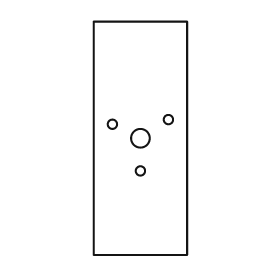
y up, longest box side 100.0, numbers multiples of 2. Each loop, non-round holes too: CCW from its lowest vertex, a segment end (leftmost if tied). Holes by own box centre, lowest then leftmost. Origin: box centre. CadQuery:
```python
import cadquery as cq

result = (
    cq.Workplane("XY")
    .moveTo(-20.0, -50.0)
    .lineTo(20.0, -50.0)
    .lineTo(20.0, 50.0)
    .lineTo(-20.0, 50.0)
    .close()
    .moveTo(0.0, -14.0)
    .circle(2.0)
    .moveTo(0.0, 0.0)
    .circle(4.0)
    .moveTo(-12.0, 6.0)
    .circle(2.0)
    .moveTo(12.0, 8.0)
    .circle(2.0)
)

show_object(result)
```